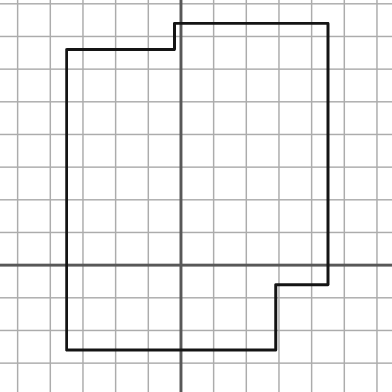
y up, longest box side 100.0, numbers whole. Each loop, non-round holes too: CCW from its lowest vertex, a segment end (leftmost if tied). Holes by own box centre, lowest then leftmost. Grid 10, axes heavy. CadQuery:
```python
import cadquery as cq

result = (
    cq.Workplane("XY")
    .moveTo(-35.0, -26.0)
    .lineTo(29.0, -26.0)
    .lineTo(29.0, -6.0)
    .lineTo(45.0, -6.0)
    .lineTo(45.0, 74.0)
    .lineTo(-2.0, 74.0)
    .lineTo(-2.0, 66.0)
    .lineTo(-35.0, 66.0)
    .close()
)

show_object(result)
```